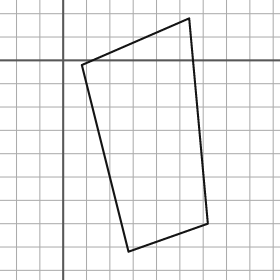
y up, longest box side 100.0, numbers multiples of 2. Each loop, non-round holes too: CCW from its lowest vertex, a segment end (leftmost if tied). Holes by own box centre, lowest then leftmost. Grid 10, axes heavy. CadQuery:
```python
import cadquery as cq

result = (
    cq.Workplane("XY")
    .moveTo(28.0, -82.0)
    .lineTo(62.0, -70.0)
    .lineTo(54.0, 18.0)
    .lineTo(8.0, -2.0)
    .close()
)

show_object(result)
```